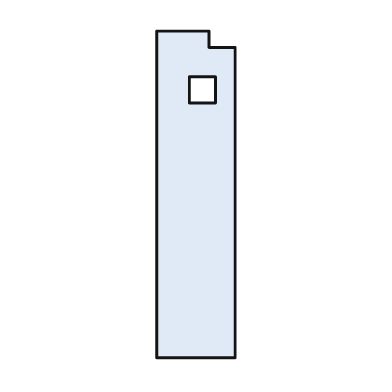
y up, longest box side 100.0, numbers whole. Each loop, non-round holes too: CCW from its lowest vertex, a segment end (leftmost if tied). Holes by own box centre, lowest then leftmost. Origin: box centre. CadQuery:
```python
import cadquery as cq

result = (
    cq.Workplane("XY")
    .moveTo(-12.0, -50.0)
    .lineTo(12.0, -50.0)
    .lineTo(12.0, 45.0)
    .lineTo(4.0, 45.0)
    .lineTo(4.0, 50.0)
    .lineTo(-12.0, 50.0)
    .close()
    .moveTo(-2.0, 28.0)
    .lineTo(6.0, 28.0)
    .lineTo(6.0, 36.0)
    .lineTo(-2.0, 36.0)
    .close()
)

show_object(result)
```